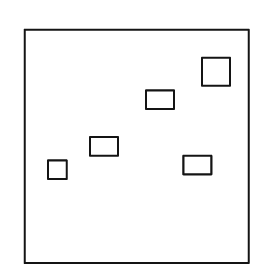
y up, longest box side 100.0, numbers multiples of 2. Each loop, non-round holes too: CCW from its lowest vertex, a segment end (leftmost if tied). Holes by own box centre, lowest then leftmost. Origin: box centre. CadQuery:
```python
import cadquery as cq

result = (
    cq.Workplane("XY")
    .moveTo(-48.0, -50.0)
    .lineTo(48.0, -50.0)
    .lineTo(48.0, 50.0)
    .lineTo(-48.0, 50.0)
    .close()
    .moveTo(-38.0, -14.0)
    .lineTo(-30.0, -14.0)
    .lineTo(-30.0, -6.0)
    .lineTo(-38.0, -6.0)
    .close()
    .moveTo(20.0, -12.0)
    .lineTo(32.0, -12.0)
    .lineTo(32.0, -4.0)
    .lineTo(20.0, -4.0)
    .close()
    .moveTo(-20.0, -4.0)
    .lineTo(-8.0, -4.0)
    .lineTo(-8.0, 4.0)
    .lineTo(-20.0, 4.0)
    .close()
    .moveTo(4.0, 16.0)
    .lineTo(16.0, 16.0)
    .lineTo(16.0, 24.0)
    .lineTo(4.0, 24.0)
    .close()
    .moveTo(28.0, 26.0)
    .lineTo(40.0, 26.0)
    .lineTo(40.0, 38.0)
    .lineTo(28.0, 38.0)
    .close()
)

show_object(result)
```